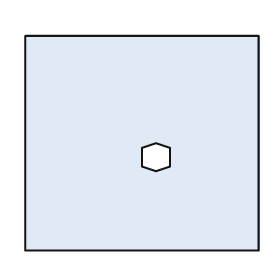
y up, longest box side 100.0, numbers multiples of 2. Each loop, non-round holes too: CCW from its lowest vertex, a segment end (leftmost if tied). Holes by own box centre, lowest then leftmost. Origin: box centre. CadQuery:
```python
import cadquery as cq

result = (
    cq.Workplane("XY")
    .moveTo(-50.0, -46.0)
    .lineTo(50.0, -46.0)
    .lineTo(50.0, 46.0)
    .lineTo(-50.0, 46.0)
    .close()
    .moveTo(6.0, -12.0)
    .lineTo(12.0, -10.0)
    .lineTo(12.0, -2.0)
    .lineTo(6.0, 0.0)
    .lineTo(0.0, -2.0)
    .lineTo(0.0, -10.0)
    .close()
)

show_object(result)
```